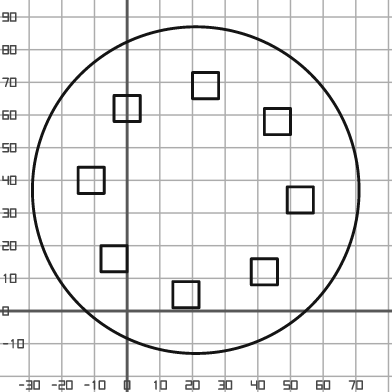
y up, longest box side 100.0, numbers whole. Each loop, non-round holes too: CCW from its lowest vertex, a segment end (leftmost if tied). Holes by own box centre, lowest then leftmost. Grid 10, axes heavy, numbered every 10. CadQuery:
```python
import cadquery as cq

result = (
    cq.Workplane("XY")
    .moveTo(21.0, 37.0)
    .circle(50.0)
    .moveTo(14.0, 1.0)
    .lineTo(22.0, 1.0)
    .lineTo(22.0, 9.0)
    .lineTo(14.0, 9.0)
    .close()
    .moveTo(38.0, 8.0)
    .lineTo(46.0, 8.0)
    .lineTo(46.0, 16.0)
    .lineTo(38.0, 16.0)
    .close()
    .moveTo(-8.0, 12.0)
    .lineTo(0.0, 12.0)
    .lineTo(0.0, 20.0)
    .lineTo(-8.0, 20.0)
    .close()
    .moveTo(49.0, 30.0)
    .lineTo(57.0, 30.0)
    .lineTo(57.0, 38.0)
    .lineTo(49.0, 38.0)
    .close()
    .moveTo(-15.0, 36.0)
    .lineTo(-7.0, 36.0)
    .lineTo(-7.0, 44.0)
    .lineTo(-15.0, 44.0)
    .close()
    .moveTo(42.0, 54.0)
    .lineTo(50.0, 54.0)
    .lineTo(50.0, 62.0)
    .lineTo(42.0, 62.0)
    .close()
    .moveTo(-4.0, 58.0)
    .lineTo(4.0, 58.0)
    .lineTo(4.0, 66.0)
    .lineTo(-4.0, 66.0)
    .close()
    .moveTo(20.0, 65.0)
    .lineTo(28.0, 65.0)
    .lineTo(28.0, 73.0)
    .lineTo(20.0, 73.0)
    .close()
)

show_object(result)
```